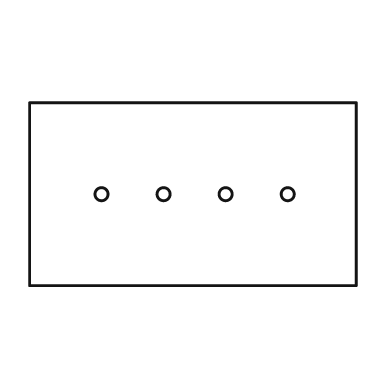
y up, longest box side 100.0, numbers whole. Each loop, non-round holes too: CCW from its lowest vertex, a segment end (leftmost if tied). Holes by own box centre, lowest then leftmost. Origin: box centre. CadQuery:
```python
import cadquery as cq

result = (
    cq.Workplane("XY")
    .moveTo(-50.0, -28.0)
    .lineTo(50.0, -28.0)
    .lineTo(50.0, 28.0)
    .lineTo(-50.0, 28.0)
    .close()
    .moveTo(-28.0, 0.0)
    .circle(2.0)
    .moveTo(-9.0, 0.0)
    .circle(2.0)
    .moveTo(10.0, 0.0)
    .circle(2.0)
    .moveTo(29.0, 0.0)
    .circle(2.0)
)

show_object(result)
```